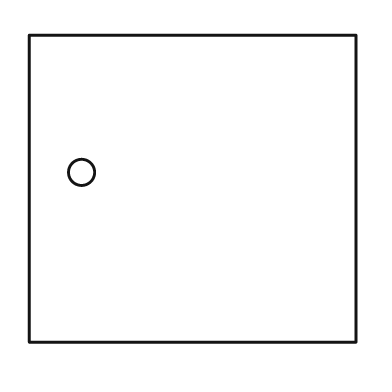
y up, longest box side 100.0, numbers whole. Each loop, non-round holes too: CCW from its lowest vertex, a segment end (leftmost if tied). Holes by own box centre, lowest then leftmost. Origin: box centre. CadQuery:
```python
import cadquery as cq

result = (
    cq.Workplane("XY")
    .moveTo(-50.0, -47.0)
    .lineTo(50.0, -47.0)
    .lineTo(50.0, 47.0)
    .lineTo(-50.0, 47.0)
    .close()
    .moveTo(-34.0, 5.0)
    .circle(4.0)
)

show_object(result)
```